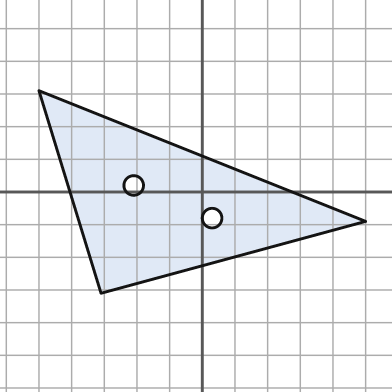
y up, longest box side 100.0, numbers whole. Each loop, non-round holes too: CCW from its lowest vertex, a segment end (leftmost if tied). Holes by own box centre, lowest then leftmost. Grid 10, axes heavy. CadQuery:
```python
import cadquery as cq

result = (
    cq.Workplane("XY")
    .moveTo(-31.0, -31.0)
    .lineTo(50.0, -9.0)
    .lineTo(-50.0, 31.0)
    .close()
    .moveTo(3.0, -8.0)
    .circle(3.0)
    .moveTo(-21.0, 2.0)
    .circle(3.0)
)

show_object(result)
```